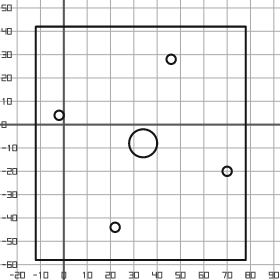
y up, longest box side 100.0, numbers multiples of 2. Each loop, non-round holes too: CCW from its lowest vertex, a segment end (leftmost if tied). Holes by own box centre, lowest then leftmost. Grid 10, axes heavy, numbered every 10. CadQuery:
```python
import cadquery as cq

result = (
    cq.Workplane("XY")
    .moveTo(-12.0, -58.0)
    .lineTo(78.0, -58.0)
    .lineTo(78.0, 42.0)
    .lineTo(-12.0, 42.0)
    .close()
    .moveTo(22.0, -44.0)
    .circle(2.0)
    .moveTo(70.0, -20.0)
    .circle(2.0)
    .moveTo(34.0, -8.0)
    .circle(6.0)
    .moveTo(-2.0, 4.0)
    .circle(2.0)
    .moveTo(46.0, 28.0)
    .circle(2.0)
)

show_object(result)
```